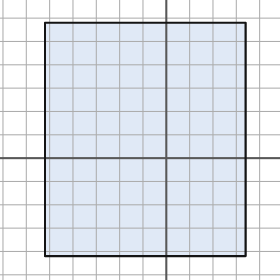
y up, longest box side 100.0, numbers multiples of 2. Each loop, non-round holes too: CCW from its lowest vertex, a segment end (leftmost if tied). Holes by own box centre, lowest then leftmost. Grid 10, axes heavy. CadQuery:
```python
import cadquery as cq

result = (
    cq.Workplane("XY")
    .moveTo(-52.0, -42.0)
    .lineTo(34.0, -42.0)
    .lineTo(34.0, 58.0)
    .lineTo(-52.0, 58.0)
    .close()
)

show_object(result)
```